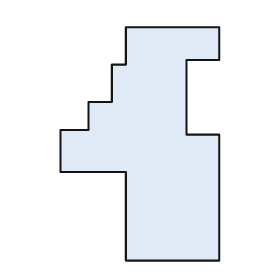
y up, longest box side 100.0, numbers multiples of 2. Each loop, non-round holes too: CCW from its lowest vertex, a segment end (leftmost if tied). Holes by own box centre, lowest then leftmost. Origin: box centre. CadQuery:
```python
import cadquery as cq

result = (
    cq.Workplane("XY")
    .moveTo(-6.0, -50.0)
    .lineTo(34.0, -50.0)
    .lineTo(34.0, 4.0)
    .lineTo(20.0, 4.0)
    .lineTo(20.0, 36.0)
    .lineTo(34.0, 36.0)
    .lineTo(34.0, 50.0)
    .lineTo(-6.0, 50.0)
    .lineTo(-6.0, 34.0)
    .lineTo(-12.0, 34.0)
    .lineTo(-12.0, 18.0)
    .lineTo(-22.0, 18.0)
    .lineTo(-22.0, 6.0)
    .lineTo(-34.0, 6.0)
    .lineTo(-34.0, -12.0)
    .lineTo(-6.0, -12.0)
    .close()
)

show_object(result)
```